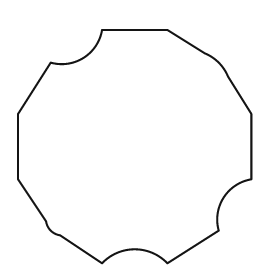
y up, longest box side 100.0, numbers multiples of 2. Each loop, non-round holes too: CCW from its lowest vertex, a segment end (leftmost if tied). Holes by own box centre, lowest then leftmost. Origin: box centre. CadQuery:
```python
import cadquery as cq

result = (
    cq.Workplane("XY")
    .moveTo(-14.0, -50.0)
    .threePointArc((0.0, -44.0), (14.0, -50.0))
    .lineTo(36.0, -36.0)
    .threePointArc((38.0, -22.0), (50.0, -14.0))
    .lineTo(50.0, 14.0)
    .lineTo(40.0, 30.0)
    .threePointArc((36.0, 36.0), (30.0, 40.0))
    .lineTo(14.0, 50.0)
    .lineTo(-14.0, 50.0)
    .threePointArc((-22.0, 38.0), (-36.0, 36.0))
    .lineTo(-50.0, 14.0)
    .lineTo(-50.0, -14.0)
    .lineTo(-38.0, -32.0)
    .threePointArc((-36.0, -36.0), (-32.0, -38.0))
    .close()
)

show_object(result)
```